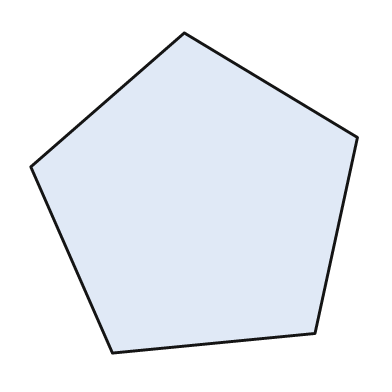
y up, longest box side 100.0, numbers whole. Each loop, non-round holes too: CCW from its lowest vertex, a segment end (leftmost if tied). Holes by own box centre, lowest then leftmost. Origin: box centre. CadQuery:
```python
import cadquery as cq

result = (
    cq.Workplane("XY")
    .moveTo(-25.0, -49.0)
    .lineTo(37.0, -43.0)
    .lineTo(50.0, 17.0)
    .lineTo(-3.0, 49.0)
    .lineTo(-50.0, 8.0)
    .close()
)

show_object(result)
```